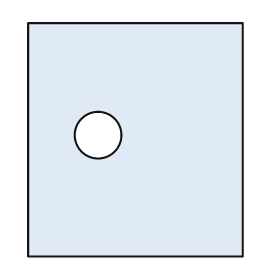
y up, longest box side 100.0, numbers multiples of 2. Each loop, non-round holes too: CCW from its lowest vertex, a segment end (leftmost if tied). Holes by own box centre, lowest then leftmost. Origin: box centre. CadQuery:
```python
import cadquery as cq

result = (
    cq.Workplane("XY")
    .moveTo(-46.0, -50.0)
    .lineTo(46.0, -50.0)
    .lineTo(46.0, 50.0)
    .lineTo(-46.0, 50.0)
    .close()
    .moveTo(-16.0, 2.0)
    .circle(10.0)
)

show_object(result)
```